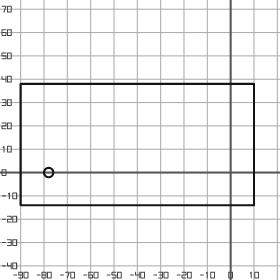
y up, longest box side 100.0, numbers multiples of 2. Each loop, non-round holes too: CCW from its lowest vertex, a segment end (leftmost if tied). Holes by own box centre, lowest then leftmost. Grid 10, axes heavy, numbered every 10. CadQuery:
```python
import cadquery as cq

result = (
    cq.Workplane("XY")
    .moveTo(-90.0, -14.0)
    .lineTo(10.0, -14.0)
    .lineTo(10.0, 38.0)
    .lineTo(-90.0, 38.0)
    .close()
    .moveTo(-78.0, 0.0)
    .circle(2.0)
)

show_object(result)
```